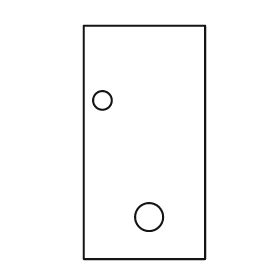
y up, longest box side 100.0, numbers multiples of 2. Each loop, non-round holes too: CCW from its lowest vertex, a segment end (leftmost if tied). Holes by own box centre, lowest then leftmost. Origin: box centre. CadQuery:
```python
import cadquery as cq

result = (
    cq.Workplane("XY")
    .moveTo(-26.0, -50.0)
    .lineTo(26.0, -50.0)
    .lineTo(26.0, 50.0)
    .lineTo(-26.0, 50.0)
    .close()
    .moveTo(2.0, -32.0)
    .circle(6.0)
    .moveTo(-18.0, 18.0)
    .circle(4.0)
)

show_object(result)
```